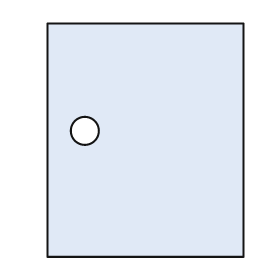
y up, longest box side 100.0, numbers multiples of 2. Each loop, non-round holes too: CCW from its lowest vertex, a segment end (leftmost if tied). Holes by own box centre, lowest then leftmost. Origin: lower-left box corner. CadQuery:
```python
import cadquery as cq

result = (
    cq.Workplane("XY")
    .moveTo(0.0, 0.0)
    .lineTo(84.0, 0.0)
    .lineTo(84.0, 100.0)
    .lineTo(0.0, 100.0)
    .close()
    .moveTo(16.0, 54.0)
    .circle(6.0)
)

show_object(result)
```